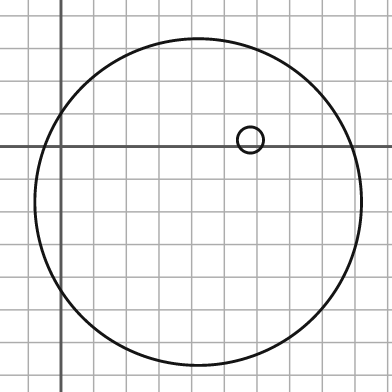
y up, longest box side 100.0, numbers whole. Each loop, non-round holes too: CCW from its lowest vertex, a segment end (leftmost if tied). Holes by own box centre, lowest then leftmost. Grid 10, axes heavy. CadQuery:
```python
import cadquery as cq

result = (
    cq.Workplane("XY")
    .moveTo(42.0, -17.0)
    .circle(50.0)
    .moveTo(58.0, 2.0)
    .circle(4.0)
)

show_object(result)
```